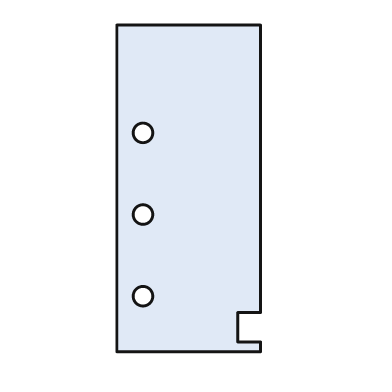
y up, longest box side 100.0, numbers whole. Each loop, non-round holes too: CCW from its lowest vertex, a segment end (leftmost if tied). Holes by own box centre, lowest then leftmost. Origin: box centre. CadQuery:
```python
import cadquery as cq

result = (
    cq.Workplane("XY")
    .moveTo(-22.0, -50.0)
    .lineTo(22.0, -50.0)
    .lineTo(22.0, -47.0)
    .lineTo(15.0, -47.0)
    .lineTo(15.0, -38.0)
    .lineTo(22.0, -38.0)
    .lineTo(22.0, 50.0)
    .lineTo(-22.0, 50.0)
    .close()
    .moveTo(-14.0, -33.0)
    .circle(3.0)
    .moveTo(-14.0, -8.0)
    .circle(3.0)
    .moveTo(-14.0, 17.0)
    .circle(3.0)
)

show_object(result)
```